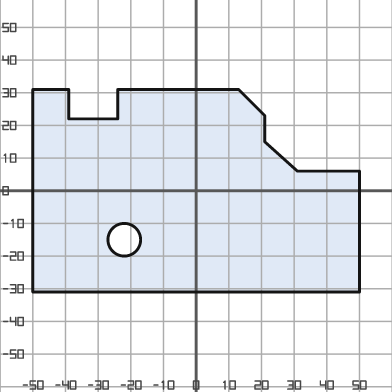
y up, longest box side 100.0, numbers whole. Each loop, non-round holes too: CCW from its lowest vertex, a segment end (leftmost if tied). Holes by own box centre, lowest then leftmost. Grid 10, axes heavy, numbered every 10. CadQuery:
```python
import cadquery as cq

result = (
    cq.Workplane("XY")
    .moveTo(-50.0, -31.0)
    .lineTo(50.0, -31.0)
    .lineTo(50.0, 6.0)
    .lineTo(31.0, 6.0)
    .lineTo(21.0, 15.0)
    .lineTo(21.0, 23.0)
    .lineTo(13.0, 31.0)
    .lineTo(-24.0, 31.0)
    .lineTo(-24.0, 22.0)
    .lineTo(-39.0, 22.0)
    .lineTo(-39.0, 31.0)
    .lineTo(-50.0, 31.0)
    .close()
    .moveTo(-22.0, -15.0)
    .circle(5.0)
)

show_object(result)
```